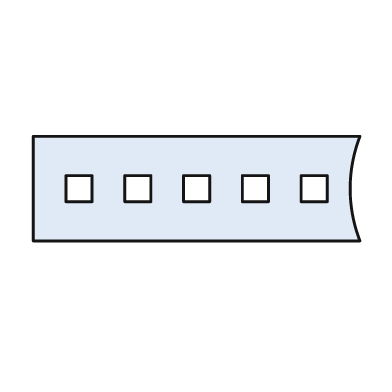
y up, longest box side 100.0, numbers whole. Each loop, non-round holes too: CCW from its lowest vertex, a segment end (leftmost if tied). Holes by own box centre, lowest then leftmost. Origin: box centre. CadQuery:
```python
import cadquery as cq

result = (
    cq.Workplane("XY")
    .moveTo(-50.0, -16.0)
    .lineTo(50.0, -16.0)
    .threePointArc((47.0, 0.0), (50.0, 16.0))
    .lineTo(-50.0, 16.0)
    .close()
    .moveTo(-40.0, -4.0)
    .lineTo(-32.0, -4.0)
    .lineTo(-32.0, 4.0)
    .lineTo(-40.0, 4.0)
    .close()
    .moveTo(-22.0, -4.0)
    .lineTo(-14.0, -4.0)
    .lineTo(-14.0, 4.0)
    .lineTo(-22.0, 4.0)
    .close()
    .moveTo(-4.0, -4.0)
    .lineTo(4.0, -4.0)
    .lineTo(4.0, 4.0)
    .lineTo(-4.0, 4.0)
    .close()
    .moveTo(14.0, -4.0)
    .lineTo(22.0, -4.0)
    .lineTo(22.0, 4.0)
    .lineTo(14.0, 4.0)
    .close()
    .moveTo(32.0, -4.0)
    .lineTo(40.0, -4.0)
    .lineTo(40.0, 4.0)
    .lineTo(32.0, 4.0)
    .close()
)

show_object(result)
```